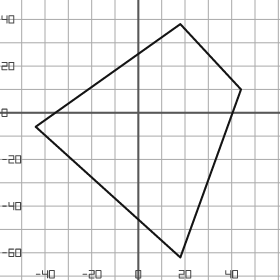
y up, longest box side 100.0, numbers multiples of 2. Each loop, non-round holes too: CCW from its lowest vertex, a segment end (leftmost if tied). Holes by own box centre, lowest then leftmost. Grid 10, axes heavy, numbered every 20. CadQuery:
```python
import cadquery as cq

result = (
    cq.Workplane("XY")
    .moveTo(18.0, -62.0)
    .lineTo(44.0, 10.0)
    .lineTo(18.0, 38.0)
    .lineTo(-44.0, -6.0)
    .close()
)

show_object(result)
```